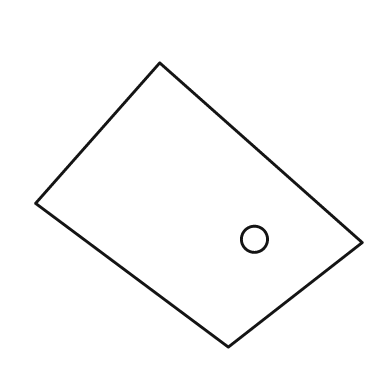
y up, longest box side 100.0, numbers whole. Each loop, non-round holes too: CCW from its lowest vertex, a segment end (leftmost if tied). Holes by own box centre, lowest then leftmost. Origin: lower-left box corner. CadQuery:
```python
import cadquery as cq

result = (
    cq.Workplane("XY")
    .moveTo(59.0, 0.0)
    .lineTo(100.0, 32.0)
    .lineTo(38.0, 87.0)
    .lineTo(0.0, 44.0)
    .close()
    .moveTo(67.0, 33.0)
    .circle(4.0)
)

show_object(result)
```